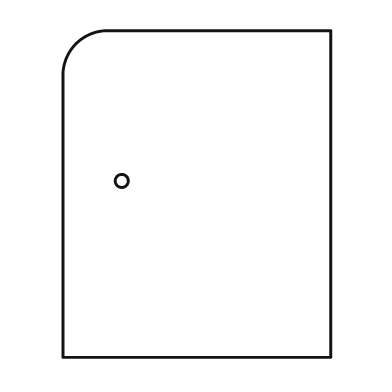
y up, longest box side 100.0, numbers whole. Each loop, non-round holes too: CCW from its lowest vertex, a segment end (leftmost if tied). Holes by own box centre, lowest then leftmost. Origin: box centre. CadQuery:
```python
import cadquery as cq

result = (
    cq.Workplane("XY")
    .moveTo(-41.0, -50.0)
    .lineTo(41.0, -50.0)
    .lineTo(41.0, 50.0)
    .lineTo(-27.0, 50.0)
    .threePointArc((-37.0, 46.0), (-41.0, 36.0))
    .close()
    .moveTo(-23.0, 4.0)
    .circle(2.0)
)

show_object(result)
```